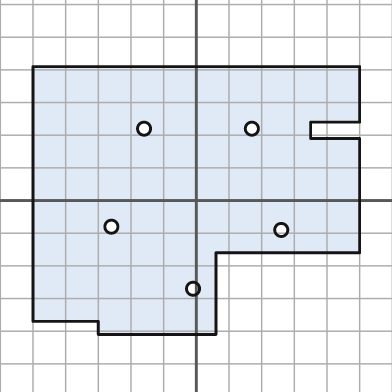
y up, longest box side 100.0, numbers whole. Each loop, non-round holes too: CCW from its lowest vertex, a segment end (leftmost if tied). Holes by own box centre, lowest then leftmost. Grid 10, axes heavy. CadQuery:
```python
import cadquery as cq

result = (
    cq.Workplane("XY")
    .moveTo(-30.0, -41.0)
    .lineTo(6.0, -41.0)
    .lineTo(6.0, -16.0)
    .lineTo(50.0, -16.0)
    .lineTo(50.0, 19.0)
    .lineTo(35.0, 19.0)
    .lineTo(35.0, 24.0)
    .lineTo(50.0, 24.0)
    .lineTo(50.0, 41.0)
    .lineTo(-50.0, 41.0)
    .lineTo(-50.0, -37.0)
    .lineTo(-30.0, -37.0)
    .close()
    .moveTo(-1.0, -27.0)
    .circle(2.0)
    .moveTo(26.0, -9.0)
    .circle(2.0)
    .moveTo(-26.0, -8.0)
    .circle(2.0)
    .moveTo(-16.0, 22.0)
    .circle(2.0)
    .moveTo(17.0, 22.0)
    .circle(2.0)
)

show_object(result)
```